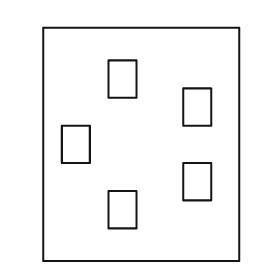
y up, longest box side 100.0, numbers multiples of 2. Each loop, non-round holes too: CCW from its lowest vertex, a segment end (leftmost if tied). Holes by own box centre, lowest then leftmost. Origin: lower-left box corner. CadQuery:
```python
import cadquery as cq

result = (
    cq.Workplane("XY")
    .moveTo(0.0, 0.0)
    .lineTo(84.0, 0.0)
    .lineTo(84.0, 100.0)
    .lineTo(0.0, 100.0)
    .close()
    .moveTo(28.0, 14.0)
    .lineTo(40.0, 14.0)
    .lineTo(40.0, 30.0)
    .lineTo(28.0, 30.0)
    .close()
    .moveTo(60.0, 26.0)
    .lineTo(72.0, 26.0)
    .lineTo(72.0, 42.0)
    .lineTo(60.0, 42.0)
    .close()
    .moveTo(8.0, 42.0)
    .lineTo(20.0, 42.0)
    .lineTo(20.0, 58.0)
    .lineTo(8.0, 58.0)
    .close()
    .moveTo(60.0, 58.0)
    .lineTo(72.0, 58.0)
    .lineTo(72.0, 74.0)
    .lineTo(60.0, 74.0)
    .close()
    .moveTo(28.0, 70.0)
    .lineTo(40.0, 70.0)
    .lineTo(40.0, 86.0)
    .lineTo(28.0, 86.0)
    .close()
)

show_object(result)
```